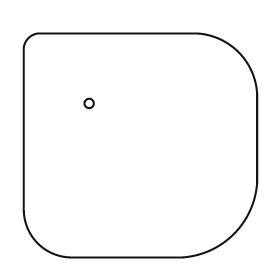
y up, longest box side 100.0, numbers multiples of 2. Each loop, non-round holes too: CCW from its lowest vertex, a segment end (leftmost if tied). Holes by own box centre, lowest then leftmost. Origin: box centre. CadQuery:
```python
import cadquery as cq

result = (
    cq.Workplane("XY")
    .moveTo(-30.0, -48.0)
    .lineTo(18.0, -48.0)
    .threePointArc((40.0, -38.0), (50.0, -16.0))
    .lineTo(50.0, 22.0)
    .threePointArc((42.0, 40.0), (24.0, 48.0))
    .lineTo(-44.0, 48.0)
    .threePointArc((-48.0, 46.0), (-50.0, 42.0))
    .lineTo(-50.0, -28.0)
    .threePointArc((-44.0, -42.0), (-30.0, -48.0))
    .close()
    .moveTo(-22.0, 18.0)
    .circle(2.0)
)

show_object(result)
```